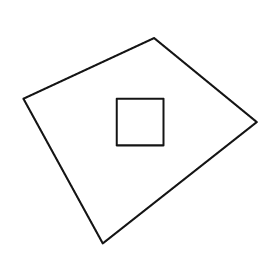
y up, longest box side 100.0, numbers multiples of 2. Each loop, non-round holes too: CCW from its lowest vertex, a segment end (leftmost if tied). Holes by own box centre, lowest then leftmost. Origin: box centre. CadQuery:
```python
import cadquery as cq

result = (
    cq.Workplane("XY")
    .moveTo(-16.0, -44.0)
    .lineTo(50.0, 8.0)
    .lineTo(6.0, 44.0)
    .lineTo(-50.0, 18.0)
    .close()
    .moveTo(-10.0, -2.0)
    .lineTo(10.0, -2.0)
    .lineTo(10.0, 18.0)
    .lineTo(-10.0, 18.0)
    .close()
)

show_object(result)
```